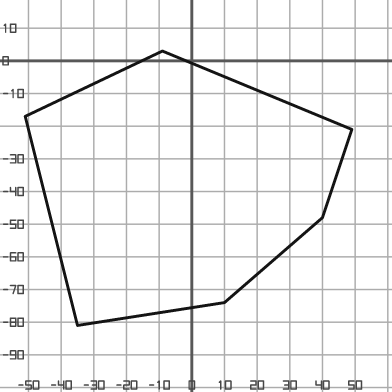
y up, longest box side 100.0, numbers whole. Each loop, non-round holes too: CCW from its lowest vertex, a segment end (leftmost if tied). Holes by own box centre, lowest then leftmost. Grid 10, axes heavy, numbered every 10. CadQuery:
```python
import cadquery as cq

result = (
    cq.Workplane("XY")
    .moveTo(-35.0, -81.0)
    .lineTo(10.0, -74.0)
    .lineTo(40.0, -48.0)
    .lineTo(49.0, -21.0)
    .lineTo(-9.0, 3.0)
    .lineTo(-51.0, -17.0)
    .close()
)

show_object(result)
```